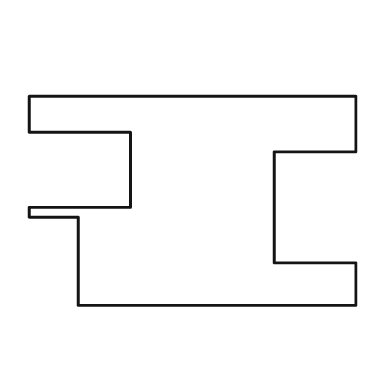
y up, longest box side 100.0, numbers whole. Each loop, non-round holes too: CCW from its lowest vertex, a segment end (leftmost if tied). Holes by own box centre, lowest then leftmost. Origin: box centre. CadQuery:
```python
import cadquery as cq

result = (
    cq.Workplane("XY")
    .moveTo(-35.0, -32.0)
    .lineTo(50.0, -32.0)
    .lineTo(50.0, -19.0)
    .lineTo(25.0, -19.0)
    .lineTo(25.0, 15.0)
    .lineTo(50.0, 15.0)
    .lineTo(50.0, 32.0)
    .lineTo(-50.0, 32.0)
    .lineTo(-50.0, 21.0)
    .lineTo(-19.0, 21.0)
    .lineTo(-19.0, -2.0)
    .lineTo(-50.0, -2.0)
    .lineTo(-50.0, -5.0)
    .lineTo(-35.0, -5.0)
    .close()
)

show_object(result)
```